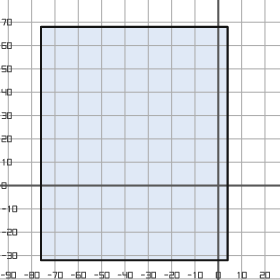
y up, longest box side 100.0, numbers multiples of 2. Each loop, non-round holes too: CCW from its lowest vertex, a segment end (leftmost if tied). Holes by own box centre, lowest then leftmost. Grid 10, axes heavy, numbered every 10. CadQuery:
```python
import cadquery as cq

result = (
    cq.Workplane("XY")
    .moveTo(-76.0, -32.0)
    .lineTo(4.0, -32.0)
    .lineTo(4.0, 68.0)
    .lineTo(-76.0, 68.0)
    .close()
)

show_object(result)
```